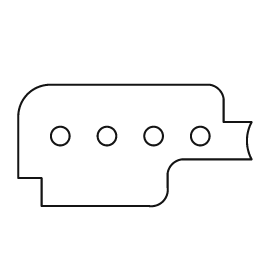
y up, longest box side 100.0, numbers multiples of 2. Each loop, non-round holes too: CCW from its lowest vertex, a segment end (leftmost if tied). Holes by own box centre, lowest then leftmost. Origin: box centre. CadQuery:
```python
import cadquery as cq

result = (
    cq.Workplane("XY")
    .moveTo(-40.0, -26.0)
    .lineTo(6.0, -26.0)
    .threePointArc((12.0, -24.0), (14.0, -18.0))
    .lineTo(14.0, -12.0)
    .threePointArc((16.0, -8.0), (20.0, -6.0))
    .lineTo(50.0, -6.0)
    .threePointArc((48.0, 2.0), (50.0, 10.0))
    .lineTo(38.0, 10.0)
    .lineTo(38.0, 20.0)
    .threePointArc((36.0, 24.0), (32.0, 26.0))
    .lineTo(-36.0, 26.0)
    .threePointArc((-46.0, 22.0), (-50.0, 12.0))
    .lineTo(-50.0, -14.0)
    .lineTo(-40.0, -14.0)
    .close()
    .moveTo(-32.0, 4.0)
    .circle(4.0)
    .moveTo(-12.0, 4.0)
    .circle(4.0)
    .moveTo(8.0, 4.0)
    .circle(4.0)
    .moveTo(28.0, 4.0)
    .circle(4.0)
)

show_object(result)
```